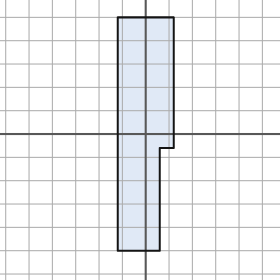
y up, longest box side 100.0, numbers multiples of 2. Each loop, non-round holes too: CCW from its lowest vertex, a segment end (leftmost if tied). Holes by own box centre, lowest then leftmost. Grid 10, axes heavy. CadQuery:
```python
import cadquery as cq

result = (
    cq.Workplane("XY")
    .moveTo(-12.0, -50.0)
    .lineTo(6.0, -50.0)
    .lineTo(6.0, -6.0)
    .lineTo(12.0, -6.0)
    .lineTo(12.0, 50.0)
    .lineTo(-12.0, 50.0)
    .close()
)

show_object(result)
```